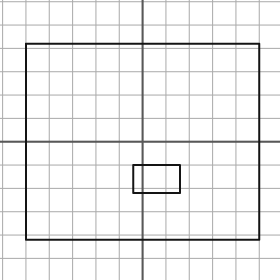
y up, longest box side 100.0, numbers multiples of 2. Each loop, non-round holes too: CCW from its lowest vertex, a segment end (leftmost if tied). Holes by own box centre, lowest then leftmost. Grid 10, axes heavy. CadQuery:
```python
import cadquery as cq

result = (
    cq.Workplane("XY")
    .moveTo(-50.0, -42.0)
    .lineTo(50.0, -42.0)
    .lineTo(50.0, 42.0)
    .lineTo(-50.0, 42.0)
    .close()
    .moveTo(-4.0, -22.0)
    .lineTo(16.0, -22.0)
    .lineTo(16.0, -10.0)
    .lineTo(-4.0, -10.0)
    .close()
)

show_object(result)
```